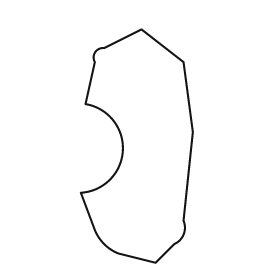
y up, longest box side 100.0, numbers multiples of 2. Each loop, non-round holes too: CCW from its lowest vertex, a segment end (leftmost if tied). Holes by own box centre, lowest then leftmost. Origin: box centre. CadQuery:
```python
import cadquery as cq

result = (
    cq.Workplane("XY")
    .moveTo(8.0, -50.0)
    .lineTo(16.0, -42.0)
    .threePointArc((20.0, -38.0), (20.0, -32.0))
    .lineTo(24.0, 6.0)
    .lineTo(20.0, 36.0)
    .lineTo(2.0, 50.0)
    .lineTo(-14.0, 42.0)
    .threePointArc((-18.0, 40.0), (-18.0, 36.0))
    .lineTo(-22.0, 18.0)
    .threePointArc((-6.0, -2.0), (-24.0, -20.0))
    .lineTo(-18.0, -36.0)
    .threePointArc((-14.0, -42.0), (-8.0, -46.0))
    .close()
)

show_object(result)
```